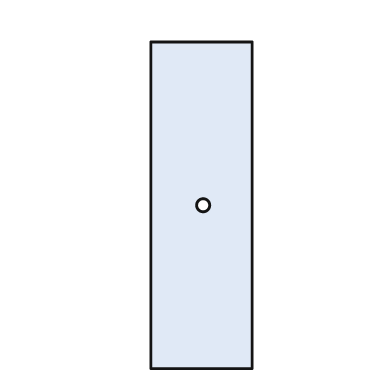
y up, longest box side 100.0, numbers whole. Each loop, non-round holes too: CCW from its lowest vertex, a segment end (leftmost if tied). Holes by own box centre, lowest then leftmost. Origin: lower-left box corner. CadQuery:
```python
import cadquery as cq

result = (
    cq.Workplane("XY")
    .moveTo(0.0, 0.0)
    .lineTo(31.0, 0.0)
    .lineTo(31.0, 100.0)
    .lineTo(0.0, 100.0)
    .close()
    .moveTo(16.0, 50.0)
    .circle(2.0)
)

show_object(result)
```